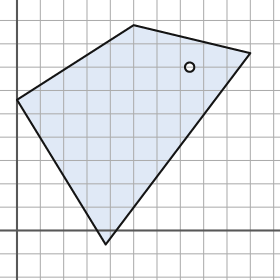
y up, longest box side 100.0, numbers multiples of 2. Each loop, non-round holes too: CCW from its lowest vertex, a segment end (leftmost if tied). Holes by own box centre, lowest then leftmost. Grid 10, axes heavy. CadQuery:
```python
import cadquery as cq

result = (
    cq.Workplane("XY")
    .moveTo(38.0, -6.0)
    .lineTo(100.0, 76.0)
    .lineTo(50.0, 88.0)
    .lineTo(0.0, 56.0)
    .close()
    .moveTo(74.0, 70.0)
    .circle(2.0)
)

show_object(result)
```